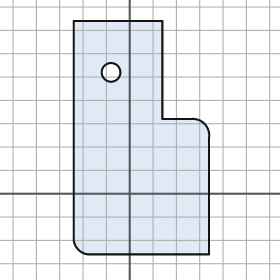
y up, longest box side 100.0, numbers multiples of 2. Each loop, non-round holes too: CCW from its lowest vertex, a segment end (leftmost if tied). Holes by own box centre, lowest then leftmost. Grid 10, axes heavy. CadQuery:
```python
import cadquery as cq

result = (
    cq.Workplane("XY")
    .moveTo(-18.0, -26.0)
    .lineTo(34.0, -26.0)
    .lineTo(34.0, 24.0)
    .threePointArc((32.0, 30.0), (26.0, 32.0))
    .lineTo(14.0, 32.0)
    .lineTo(14.0, 74.0)
    .lineTo(-24.0, 74.0)
    .lineTo(-24.0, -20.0)
    .threePointArc((-22.0, -24.0), (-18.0, -26.0))
    .close()
    .moveTo(-8.0, 52.0)
    .circle(4.0)
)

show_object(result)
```